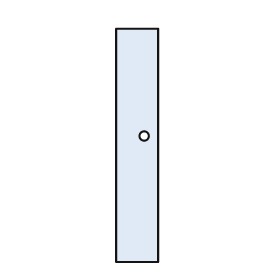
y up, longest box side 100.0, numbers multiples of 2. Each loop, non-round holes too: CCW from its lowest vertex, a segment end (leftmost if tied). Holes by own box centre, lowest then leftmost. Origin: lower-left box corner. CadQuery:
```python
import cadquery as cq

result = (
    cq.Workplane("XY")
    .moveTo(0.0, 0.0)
    .lineTo(18.0, 0.0)
    .lineTo(18.0, 100.0)
    .lineTo(0.0, 100.0)
    .close()
    .moveTo(12.0, 54.0)
    .circle(2.0)
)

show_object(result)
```